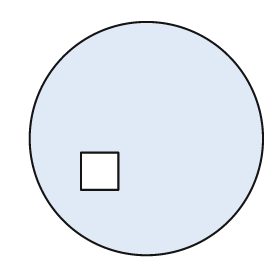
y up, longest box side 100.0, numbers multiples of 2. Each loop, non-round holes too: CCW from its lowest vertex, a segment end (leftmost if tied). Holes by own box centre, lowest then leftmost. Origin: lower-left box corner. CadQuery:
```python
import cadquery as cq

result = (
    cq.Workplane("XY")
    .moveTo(50.0, 50.0)
    .circle(50.0)
    .moveTo(22.0, 28.0)
    .lineTo(38.0, 28.0)
    .lineTo(38.0, 44.0)
    .lineTo(22.0, 44.0)
    .close()
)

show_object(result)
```